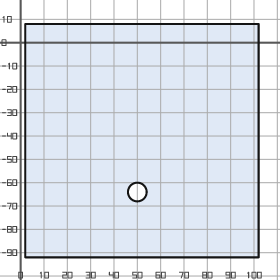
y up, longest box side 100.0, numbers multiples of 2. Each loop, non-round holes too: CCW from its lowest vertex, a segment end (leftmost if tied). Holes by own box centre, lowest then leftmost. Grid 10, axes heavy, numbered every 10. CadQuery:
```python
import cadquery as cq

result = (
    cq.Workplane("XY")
    .moveTo(2.0, -92.0)
    .lineTo(102.0, -92.0)
    .lineTo(102.0, 8.0)
    .lineTo(2.0, 8.0)
    .close()
    .moveTo(50.0, -64.0)
    .circle(4.0)
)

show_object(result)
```